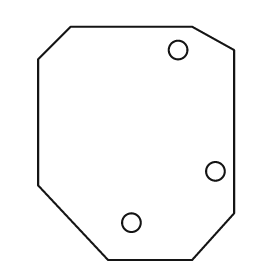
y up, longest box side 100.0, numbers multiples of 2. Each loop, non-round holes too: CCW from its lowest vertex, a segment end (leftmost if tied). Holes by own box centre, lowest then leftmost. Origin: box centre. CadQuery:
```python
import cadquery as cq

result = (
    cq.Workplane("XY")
    .moveTo(-12.0, -50.0)
    .lineTo(24.0, -50.0)
    .lineTo(42.0, -30.0)
    .lineTo(42.0, 40.0)
    .lineTo(24.0, 50.0)
    .lineTo(-28.0, 50.0)
    .lineTo(-42.0, 36.0)
    .lineTo(-42.0, -18.0)
    .close()
    .moveTo(-2.0, -34.0)
    .circle(4.0)
    .moveTo(34.0, -12.0)
    .circle(4.0)
    .moveTo(18.0, 40.0)
    .circle(4.0)
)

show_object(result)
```